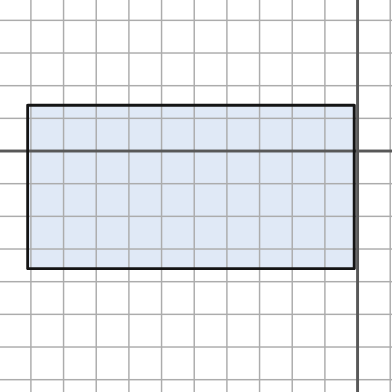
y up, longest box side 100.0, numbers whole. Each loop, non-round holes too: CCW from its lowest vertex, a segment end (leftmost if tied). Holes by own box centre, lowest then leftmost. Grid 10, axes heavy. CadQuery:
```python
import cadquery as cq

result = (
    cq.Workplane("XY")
    .moveTo(-101.0, -36.0)
    .lineTo(-1.0, -36.0)
    .lineTo(-1.0, 14.0)
    .lineTo(-101.0, 14.0)
    .close()
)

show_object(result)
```